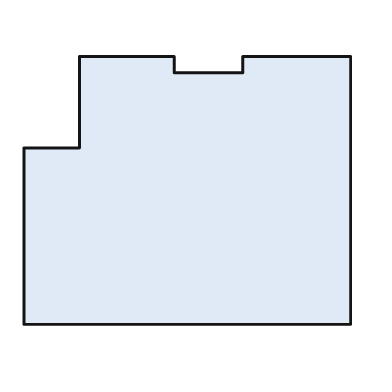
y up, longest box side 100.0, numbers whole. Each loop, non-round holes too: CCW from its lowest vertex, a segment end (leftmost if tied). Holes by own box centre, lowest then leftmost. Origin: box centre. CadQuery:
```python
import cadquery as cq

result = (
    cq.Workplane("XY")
    .moveTo(-50.0, -41.0)
    .lineTo(50.0, -41.0)
    .lineTo(50.0, 41.0)
    .lineTo(17.0, 41.0)
    .lineTo(17.0, 36.0)
    .lineTo(-4.0, 36.0)
    .lineTo(-4.0, 41.0)
    .lineTo(-33.0, 41.0)
    .lineTo(-33.0, 13.0)
    .lineTo(-50.0, 13.0)
    .close()
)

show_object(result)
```